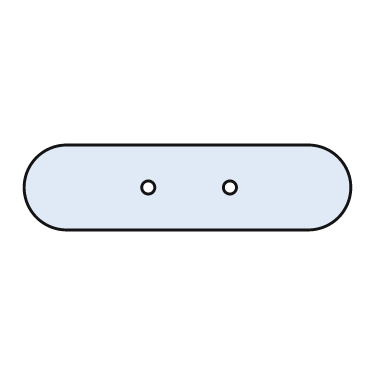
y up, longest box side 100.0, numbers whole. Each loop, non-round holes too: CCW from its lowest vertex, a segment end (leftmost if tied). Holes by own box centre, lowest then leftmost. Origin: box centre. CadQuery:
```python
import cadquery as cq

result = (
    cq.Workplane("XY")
    .moveTo(-37.0, -13.0)
    .lineTo(37.0, -13.0)
    .threePointArc((50.0, 0.0), (37.0, 13.0))
    .lineTo(-37.0, 13.0)
    .threePointArc((-50.0, 0.0), (-37.0, -13.0))
    .close()
    .moveTo(-12.0, 0.0)
    .circle(2.0)
    .moveTo(13.0, 0.0)
    .circle(2.0)
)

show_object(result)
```